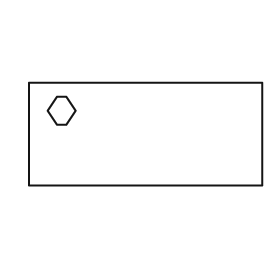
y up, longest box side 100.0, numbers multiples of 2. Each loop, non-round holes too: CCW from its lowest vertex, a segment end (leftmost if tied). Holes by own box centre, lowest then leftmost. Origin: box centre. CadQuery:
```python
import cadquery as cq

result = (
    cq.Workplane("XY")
    .moveTo(-50.0, -22.0)
    .lineTo(50.0, -22.0)
    .lineTo(50.0, 22.0)
    .lineTo(-50.0, 22.0)
    .close()
    .moveTo(-38.0, 4.0)
    .lineTo(-34.0, 4.0)
    .lineTo(-30.0, 10.0)
    .lineTo(-34.0, 16.0)
    .lineTo(-38.0, 16.0)
    .lineTo(-42.0, 10.0)
    .close()
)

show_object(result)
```